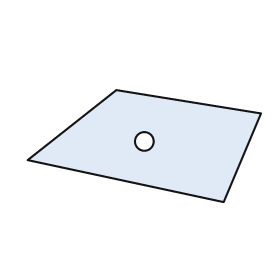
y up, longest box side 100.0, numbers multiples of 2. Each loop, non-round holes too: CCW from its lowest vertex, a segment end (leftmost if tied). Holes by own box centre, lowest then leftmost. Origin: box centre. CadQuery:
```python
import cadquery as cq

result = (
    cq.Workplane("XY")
    .moveTo(34.0, -24.0)
    .lineTo(50.0, 14.0)
    .lineTo(-12.0, 24.0)
    .lineTo(-50.0, -6.0)
    .close()
    .moveTo(0.0, 2.0)
    .circle(4.0)
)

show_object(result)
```